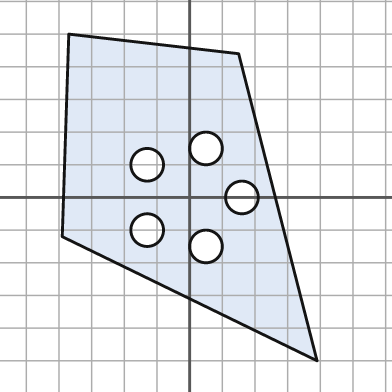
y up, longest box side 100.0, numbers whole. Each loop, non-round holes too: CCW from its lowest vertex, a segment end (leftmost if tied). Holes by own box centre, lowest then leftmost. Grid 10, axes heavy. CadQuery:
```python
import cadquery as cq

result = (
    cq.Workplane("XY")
    .moveTo(39.0, -50.0)
    .lineTo(15.0, 44.0)
    .lineTo(-37.0, 50.0)
    .lineTo(-39.0, -12.0)
    .close()
    .moveTo(5.0, -15.0)
    .circle(5.0)
    .moveTo(-13.0, -10.0)
    .circle(5.0)
    .moveTo(16.0, 0.0)
    .circle(5.0)
    .moveTo(-13.0, 10.0)
    .circle(5.0)
    .moveTo(5.0, 15.0)
    .circle(5.0)
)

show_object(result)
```